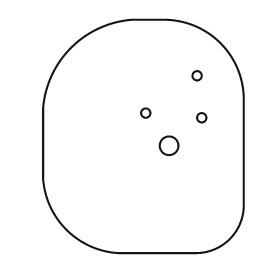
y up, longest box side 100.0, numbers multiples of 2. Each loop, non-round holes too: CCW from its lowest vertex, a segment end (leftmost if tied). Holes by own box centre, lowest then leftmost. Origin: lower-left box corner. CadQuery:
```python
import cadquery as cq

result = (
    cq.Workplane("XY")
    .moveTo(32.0, 0.0)
    .lineTo(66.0, 0.0)
    .threePointArc((80.0, 6.0), (86.0, 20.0))
    .lineTo(86.0, 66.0)
    .threePointArc((76.0, 90.0), (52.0, 100.0))
    .lineTo(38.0, 100.0)
    .threePointArc((12.0, 88.0), (0.0, 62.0))
    .lineTo(0.0, 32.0)
    .threePointArc((10.0, 10.0), (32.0, 0.0))
    .close()
    .moveTo(54.0, 46.0)
    .circle(4.0)
    .moveTo(68.0, 58.0)
    .circle(2.0)
    .moveTo(44.0, 60.0)
    .circle(2.0)
    .moveTo(66.0, 76.0)
    .circle(2.0)
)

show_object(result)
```